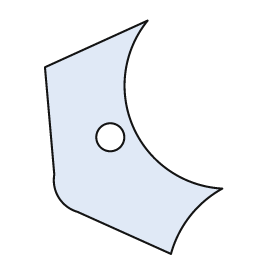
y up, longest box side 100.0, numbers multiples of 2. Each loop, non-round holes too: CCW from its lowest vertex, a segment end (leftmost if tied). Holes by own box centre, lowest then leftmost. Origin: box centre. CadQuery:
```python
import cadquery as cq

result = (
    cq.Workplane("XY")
    .moveTo(16.0, -50.0)
    .threePointArc((24.0, -34.0), (38.0, -22.0))
    .threePointArc((0.0, 4.0), (6.0, 50.0))
    .lineTo(-38.0, 30.0)
    .lineTo(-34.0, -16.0)
    .threePointArc((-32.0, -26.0), (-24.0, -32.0))
    .close()
    .moveTo(-10.0, 0.0)
    .circle(6.0)
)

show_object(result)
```